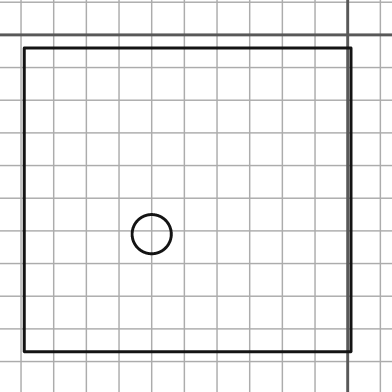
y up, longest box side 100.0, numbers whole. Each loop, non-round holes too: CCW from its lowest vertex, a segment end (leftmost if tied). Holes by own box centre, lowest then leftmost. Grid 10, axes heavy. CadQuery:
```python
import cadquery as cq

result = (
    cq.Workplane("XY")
    .moveTo(-99.0, -97.0)
    .lineTo(1.0, -97.0)
    .lineTo(1.0, -4.0)
    .lineTo(-99.0, -4.0)
    .close()
    .moveTo(-60.0, -61.0)
    .circle(6.0)
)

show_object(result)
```